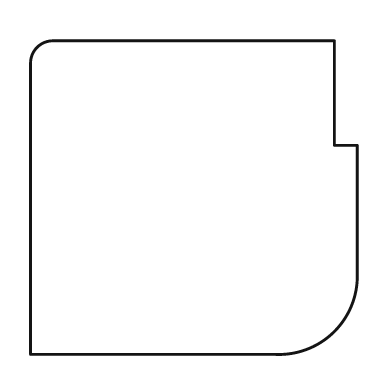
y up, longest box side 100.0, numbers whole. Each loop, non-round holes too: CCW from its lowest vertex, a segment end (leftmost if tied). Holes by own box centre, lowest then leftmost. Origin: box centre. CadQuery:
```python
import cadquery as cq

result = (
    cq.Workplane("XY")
    .moveTo(-50.0, -48.0)
    .lineTo(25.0, -48.0)
    .threePointArc((43.0, -41.0), (50.0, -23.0))
    .lineTo(50.0, 16.0)
    .lineTo(43.0, 16.0)
    .lineTo(43.0, 48.0)
    .lineTo(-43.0, 48.0)
    .threePointArc((-48.0, 46.0), (-50.0, 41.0))
    .close()
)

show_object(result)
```